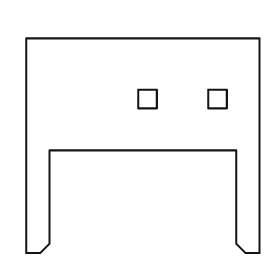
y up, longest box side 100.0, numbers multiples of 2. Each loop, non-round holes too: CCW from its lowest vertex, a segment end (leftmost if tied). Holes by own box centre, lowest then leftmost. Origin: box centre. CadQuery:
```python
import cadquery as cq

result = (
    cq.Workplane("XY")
    .moveTo(-50.0, -46.0)
    .lineTo(-44.0, -46.0)
    .lineTo(-40.0, -42.0)
    .lineTo(-40.0, -2.0)
    .lineTo(40.0, -2.0)
    .lineTo(40.0, -42.0)
    .lineTo(44.0, -46.0)
    .lineTo(50.0, -46.0)
    .lineTo(50.0, 46.0)
    .lineTo(-50.0, 46.0)
    .close()
    .moveTo(-2.0, 16.0)
    .lineTo(6.0, 16.0)
    .lineTo(6.0, 24.0)
    .lineTo(-2.0, 24.0)
    .close()
    .moveTo(28.0, 16.0)
    .lineTo(36.0, 16.0)
    .lineTo(36.0, 24.0)
    .lineTo(28.0, 24.0)
    .close()
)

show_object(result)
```